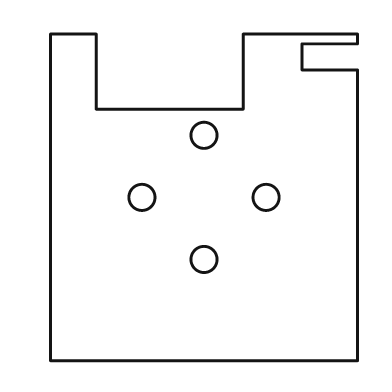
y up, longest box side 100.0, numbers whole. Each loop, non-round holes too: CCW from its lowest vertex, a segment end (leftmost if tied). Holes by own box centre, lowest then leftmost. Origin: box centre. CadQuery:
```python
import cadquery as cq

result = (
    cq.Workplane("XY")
    .moveTo(-47.0, -50.0)
    .lineTo(47.0, -50.0)
    .lineTo(47.0, 39.0)
    .lineTo(30.0, 39.0)
    .lineTo(30.0, 47.0)
    .lineTo(47.0, 47.0)
    .lineTo(47.0, 50.0)
    .lineTo(12.0, 50.0)
    .lineTo(12.0, 27.0)
    .lineTo(-33.0, 27.0)
    .lineTo(-33.0, 50.0)
    .lineTo(-47.0, 50.0)
    .close()
    .moveTo(0.0, -19.0)
    .circle(4.0)
    .moveTo(-19.0, 0.0)
    .circle(4.0)
    .moveTo(19.0, 0.0)
    .circle(4.0)
    .moveTo(0.0, 19.0)
    .circle(4.0)
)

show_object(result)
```